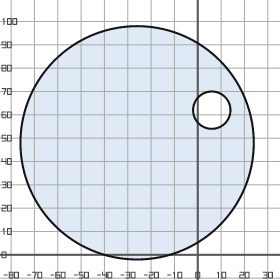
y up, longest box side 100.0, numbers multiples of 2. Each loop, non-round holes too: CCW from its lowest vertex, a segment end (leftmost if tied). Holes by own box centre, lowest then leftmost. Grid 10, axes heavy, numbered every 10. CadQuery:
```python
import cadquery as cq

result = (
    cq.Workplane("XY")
    .moveTo(-26.0, 48.0)
    .circle(50.0)
    .moveTo(6.0, 62.0)
    .circle(8.0)
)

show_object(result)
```